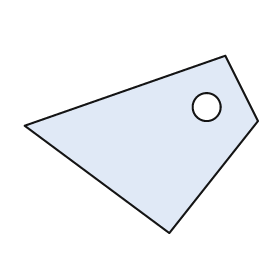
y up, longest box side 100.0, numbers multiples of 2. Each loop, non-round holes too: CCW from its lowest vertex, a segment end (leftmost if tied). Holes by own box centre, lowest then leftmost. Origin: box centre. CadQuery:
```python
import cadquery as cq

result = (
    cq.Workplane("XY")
    .moveTo(12.0, -38.0)
    .lineTo(50.0, 10.0)
    .lineTo(36.0, 38.0)
    .lineTo(-50.0, 8.0)
    .close()
    .moveTo(28.0, 16.0)
    .circle(6.0)
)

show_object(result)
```